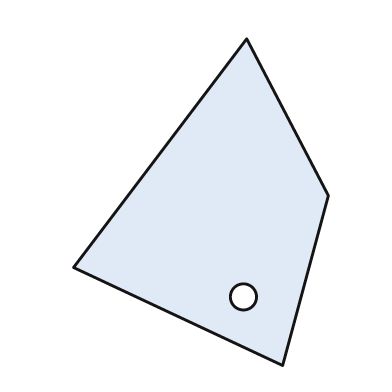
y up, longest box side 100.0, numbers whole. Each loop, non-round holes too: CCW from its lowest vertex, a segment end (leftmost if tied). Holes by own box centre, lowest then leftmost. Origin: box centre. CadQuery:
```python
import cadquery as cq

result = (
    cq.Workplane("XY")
    .moveTo(25.0, -50.0)
    .lineTo(39.0, 2.0)
    .lineTo(14.0, 50.0)
    .lineTo(-39.0, -20.0)
    .close()
    .moveTo(13.0, -29.0)
    .circle(4.0)
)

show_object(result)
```